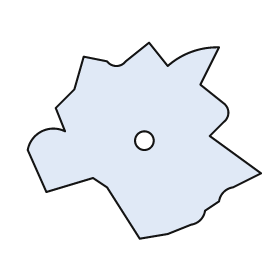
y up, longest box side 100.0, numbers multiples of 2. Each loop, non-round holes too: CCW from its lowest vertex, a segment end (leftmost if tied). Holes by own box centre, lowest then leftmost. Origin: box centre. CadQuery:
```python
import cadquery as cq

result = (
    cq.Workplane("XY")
    .moveTo(-2.0, -42.0)
    .lineTo(10.0, -40.0)
    .lineTo(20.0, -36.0)
    .threePointArc((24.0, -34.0), (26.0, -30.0))
    .lineTo(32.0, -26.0)
    .threePointArc((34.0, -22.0), (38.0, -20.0))
    .lineTo(50.0, -14.0)
    .lineTo(28.0, 2.0)
    .lineTo(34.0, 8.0)
    .threePointArc((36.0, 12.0), (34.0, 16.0))
    .lineTo(24.0, 24.0)
    .lineTo(32.0, 40.0)
    .threePointArc((20.0, 38.0), (10.0, 32.0))
    .lineTo(2.0, 42.0)
    .lineTo(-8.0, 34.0)
    .threePointArc((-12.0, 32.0), (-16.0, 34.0))
    .lineTo(-26.0, 36.0)
    .lineTo(-30.0, 22.0)
    .lineTo(-38.0, 14.0)
    .lineTo(-34.0, 4.0)
    .threePointArc((-44.0, 4.0), (-50.0, -4.0))
    .lineTo(-42.0, -22.0)
    .lineTo(-22.0, -16.0)
    .lineTo(-16.0, -20.0)
    .close()
    .moveTo(0.0, 0.0)
    .circle(4.0)
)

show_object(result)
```